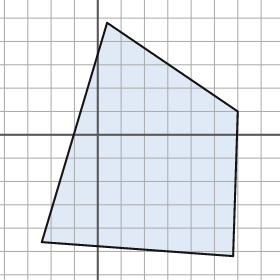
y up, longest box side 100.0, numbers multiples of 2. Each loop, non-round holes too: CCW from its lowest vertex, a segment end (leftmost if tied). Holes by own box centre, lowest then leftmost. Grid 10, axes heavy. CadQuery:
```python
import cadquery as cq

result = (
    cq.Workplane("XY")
    .moveTo(58.0, -52.0)
    .lineTo(60.0, 10.0)
    .lineTo(4.0, 48.0)
    .lineTo(-24.0, -46.0)
    .close()
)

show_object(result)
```